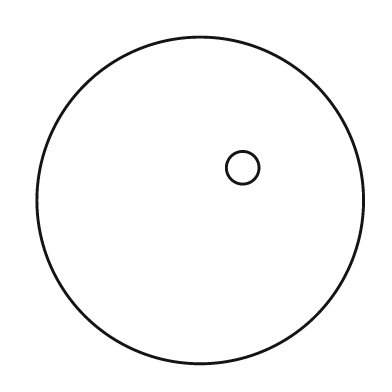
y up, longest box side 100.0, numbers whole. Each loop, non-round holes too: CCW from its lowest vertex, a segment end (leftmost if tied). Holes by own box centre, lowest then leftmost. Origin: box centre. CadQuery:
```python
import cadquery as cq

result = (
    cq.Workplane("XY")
    .moveTo(0.0, 0.0)
    .circle(50.0)
    .moveTo(13.0, 10.0)
    .circle(5.0)
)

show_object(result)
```